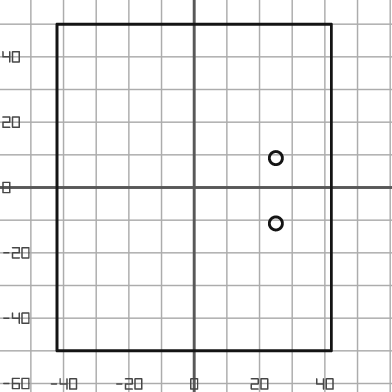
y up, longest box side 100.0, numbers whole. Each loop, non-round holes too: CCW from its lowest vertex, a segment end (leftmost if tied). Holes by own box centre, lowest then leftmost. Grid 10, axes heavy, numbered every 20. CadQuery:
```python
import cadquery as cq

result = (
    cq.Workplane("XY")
    .moveTo(-42.0, -50.0)
    .lineTo(42.0, -50.0)
    .lineTo(42.0, 50.0)
    .lineTo(-42.0, 50.0)
    .close()
    .moveTo(25.0, -11.0)
    .circle(2.0)
    .moveTo(25.0, 9.0)
    .circle(2.0)
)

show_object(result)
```